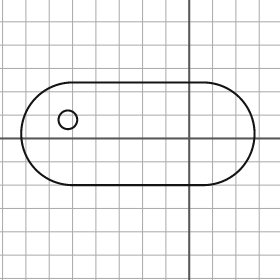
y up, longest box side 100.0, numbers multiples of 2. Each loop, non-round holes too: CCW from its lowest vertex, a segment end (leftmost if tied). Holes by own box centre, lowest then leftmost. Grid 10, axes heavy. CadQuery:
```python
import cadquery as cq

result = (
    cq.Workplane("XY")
    .moveTo(-50.0, -20.0)
    .lineTo(6.0, -20.0)
    .threePointArc((28.0, 2.0), (6.0, 24.0))
    .lineTo(-50.0, 24.0)
    .threePointArc((-72.0, 2.0), (-50.0, -20.0))
    .close()
    .moveTo(-52.0, 8.0)
    .circle(4.0)
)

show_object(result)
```